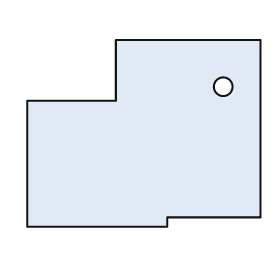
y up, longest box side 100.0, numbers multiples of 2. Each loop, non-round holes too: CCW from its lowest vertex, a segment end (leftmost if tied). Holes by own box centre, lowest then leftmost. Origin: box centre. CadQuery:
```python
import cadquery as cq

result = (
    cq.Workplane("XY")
    .moveTo(-50.0, -40.0)
    .lineTo(10.0, -40.0)
    .lineTo(10.0, -36.0)
    .lineTo(50.0, -36.0)
    .lineTo(50.0, 40.0)
    .lineTo(-12.0, 40.0)
    .lineTo(-12.0, 14.0)
    .lineTo(-50.0, 14.0)
    .close()
    .moveTo(34.0, 20.0)
    .circle(4.0)
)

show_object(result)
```